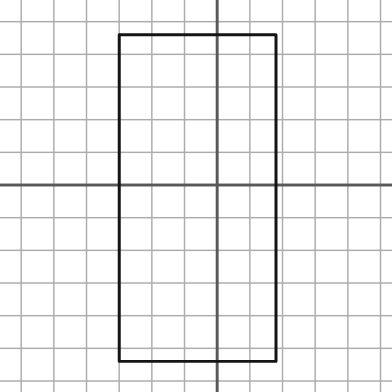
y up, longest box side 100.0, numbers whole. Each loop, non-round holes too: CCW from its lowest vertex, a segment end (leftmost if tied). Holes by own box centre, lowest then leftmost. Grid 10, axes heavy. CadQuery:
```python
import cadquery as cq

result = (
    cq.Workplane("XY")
    .moveTo(-30.0, -54.0)
    .lineTo(18.0, -54.0)
    .lineTo(18.0, 46.0)
    .lineTo(-30.0, 46.0)
    .close()
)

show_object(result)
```